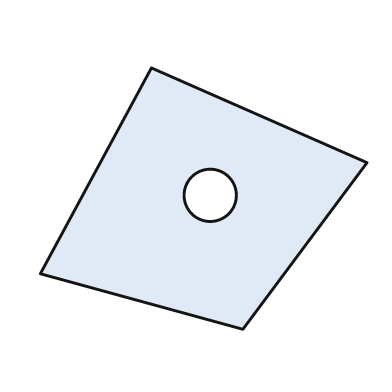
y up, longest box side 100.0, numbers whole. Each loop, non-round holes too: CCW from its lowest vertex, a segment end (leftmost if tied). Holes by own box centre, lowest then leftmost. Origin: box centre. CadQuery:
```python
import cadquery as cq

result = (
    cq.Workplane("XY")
    .moveTo(12.0, -40.0)
    .lineTo(50.0, 11.0)
    .lineTo(-16.0, 40.0)
    .lineTo(-50.0, -23.0)
    .close()
    .moveTo(2.0, 1.0)
    .circle(8.0)
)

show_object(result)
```